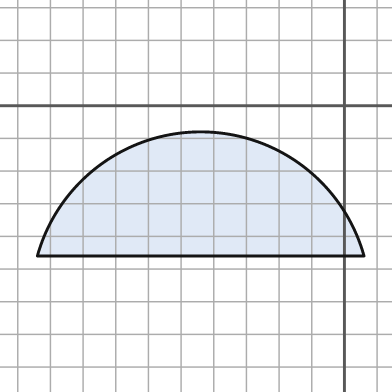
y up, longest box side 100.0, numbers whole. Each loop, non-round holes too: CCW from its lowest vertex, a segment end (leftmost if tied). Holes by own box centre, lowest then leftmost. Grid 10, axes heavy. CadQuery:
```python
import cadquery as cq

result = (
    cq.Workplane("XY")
    .moveTo(-94.0, -46.0)
    .lineTo(6.0, -46.0)
    .threePointArc((-44.0, -8.0), (-94.0, -46.0))
    .close()
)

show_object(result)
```